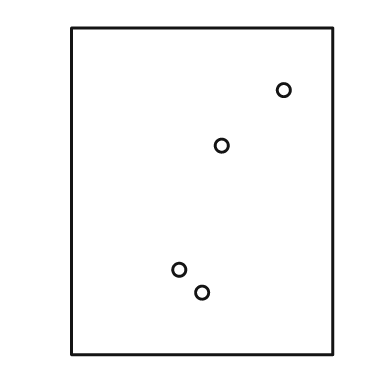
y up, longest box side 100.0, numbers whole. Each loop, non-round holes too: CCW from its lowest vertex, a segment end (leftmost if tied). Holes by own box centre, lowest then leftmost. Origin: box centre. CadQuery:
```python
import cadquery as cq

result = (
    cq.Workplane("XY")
    .moveTo(-40.0, -50.0)
    .lineTo(40.0, -50.0)
    .lineTo(40.0, 50.0)
    .lineTo(-40.0, 50.0)
    .close()
    .moveTo(0.0, -31.0)
    .circle(2.0)
    .moveTo(-7.0, -24.0)
    .circle(2.0)
    .moveTo(6.0, 14.0)
    .circle(2.0)
    .moveTo(25.0, 31.0)
    .circle(2.0)
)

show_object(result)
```